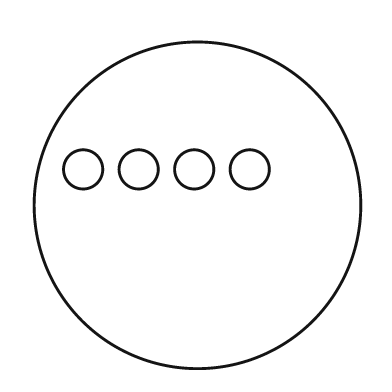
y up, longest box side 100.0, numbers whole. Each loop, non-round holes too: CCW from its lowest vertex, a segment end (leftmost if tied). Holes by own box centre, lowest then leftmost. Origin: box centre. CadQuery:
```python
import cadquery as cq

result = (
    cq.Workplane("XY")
    .moveTo(0.0, 0.0)
    .circle(50.0)
    .moveTo(-35.0, 11.0)
    .circle(6.0)
    .moveTo(-18.0, 11.0)
    .circle(6.0)
    .moveTo(-1.0, 11.0)
    .circle(6.0)
    .moveTo(16.0, 11.0)
    .circle(6.0)
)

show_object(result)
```